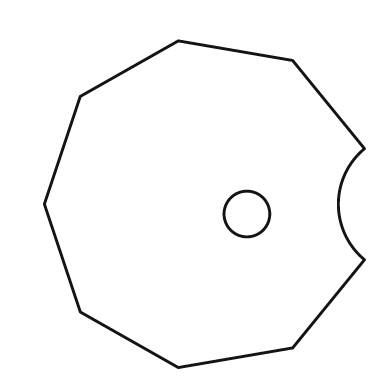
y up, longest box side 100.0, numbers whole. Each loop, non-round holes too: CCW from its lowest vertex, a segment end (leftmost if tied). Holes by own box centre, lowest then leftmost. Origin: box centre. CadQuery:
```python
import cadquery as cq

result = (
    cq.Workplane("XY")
    .moveTo(-8.0, -50.0)
    .lineTo(27.0, -44.0)
    .lineTo(49.0, -17.0)
    .threePointArc((41.0, 0.0), (49.0, 17.0))
    .lineTo(27.0, 44.0)
    .lineTo(-8.0, 50.0)
    .lineTo(-38.0, 33.0)
    .lineTo(-49.0, 0.0)
    .lineTo(-38.0, -33.0)
    .close()
    .moveTo(13.0, -3.0)
    .circle(7.0)
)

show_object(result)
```